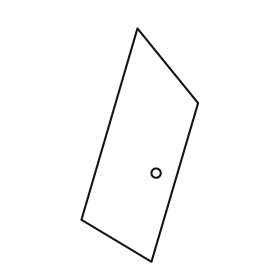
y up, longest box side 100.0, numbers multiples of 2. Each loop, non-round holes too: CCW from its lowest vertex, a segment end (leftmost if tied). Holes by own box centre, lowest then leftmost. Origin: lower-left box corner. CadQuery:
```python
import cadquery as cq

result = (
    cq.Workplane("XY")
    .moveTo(30.0, 0.0)
    .lineTo(50.0, 68.0)
    .lineTo(24.0, 100.0)
    .lineTo(0.0, 18.0)
    .close()
    .moveTo(32.0, 38.0)
    .circle(2.0)
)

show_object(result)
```